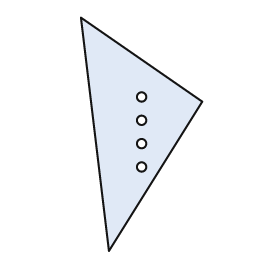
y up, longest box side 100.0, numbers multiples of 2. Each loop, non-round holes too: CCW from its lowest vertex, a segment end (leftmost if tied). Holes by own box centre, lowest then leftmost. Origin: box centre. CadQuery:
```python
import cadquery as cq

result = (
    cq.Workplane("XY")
    .moveTo(-14.0, -50.0)
    .lineTo(26.0, 14.0)
    .lineTo(-26.0, 50.0)
    .close()
    .moveTo(0.0, -14.0)
    .circle(2.0)
    .moveTo(0.0, -4.0)
    .circle(2.0)
    .moveTo(0.0, 6.0)
    .circle(2.0)
    .moveTo(0.0, 16.0)
    .circle(2.0)
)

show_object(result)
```